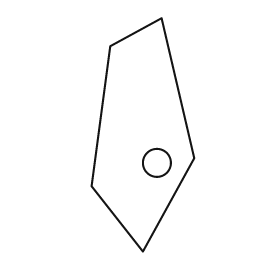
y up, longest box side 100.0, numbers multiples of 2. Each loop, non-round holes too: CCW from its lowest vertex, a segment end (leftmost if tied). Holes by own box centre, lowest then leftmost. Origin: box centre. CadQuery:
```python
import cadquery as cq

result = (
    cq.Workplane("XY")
    .moveTo(0.0, -50.0)
    .lineTo(22.0, -10.0)
    .lineTo(8.0, 50.0)
    .lineTo(-14.0, 38.0)
    .lineTo(-22.0, -22.0)
    .close()
    .moveTo(6.0, -12.0)
    .circle(6.0)
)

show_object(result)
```